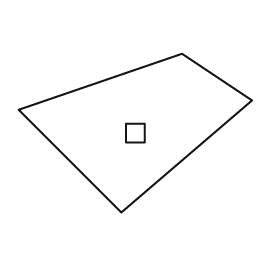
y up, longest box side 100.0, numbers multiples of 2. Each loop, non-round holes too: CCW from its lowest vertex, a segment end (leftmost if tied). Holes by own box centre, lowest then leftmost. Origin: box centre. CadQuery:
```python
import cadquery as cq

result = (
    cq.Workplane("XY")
    .moveTo(-6.0, -34.0)
    .lineTo(50.0, 14.0)
    .lineTo(20.0, 34.0)
    .lineTo(-50.0, 10.0)
    .close()
    .moveTo(-4.0, -4.0)
    .lineTo(4.0, -4.0)
    .lineTo(4.0, 4.0)
    .lineTo(-4.0, 4.0)
    .close()
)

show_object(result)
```